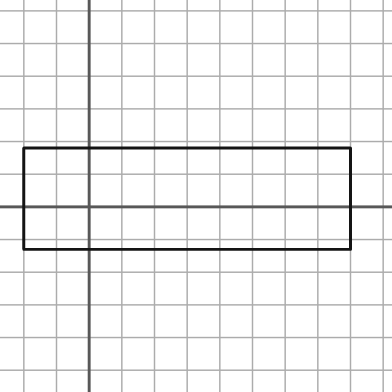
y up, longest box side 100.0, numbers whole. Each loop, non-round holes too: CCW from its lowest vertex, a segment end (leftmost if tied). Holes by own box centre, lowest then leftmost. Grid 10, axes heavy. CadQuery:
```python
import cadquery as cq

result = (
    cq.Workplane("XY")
    .moveTo(-20.0, -13.0)
    .lineTo(80.0, -13.0)
    .lineTo(80.0, 18.0)
    .lineTo(-20.0, 18.0)
    .close()
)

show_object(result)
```